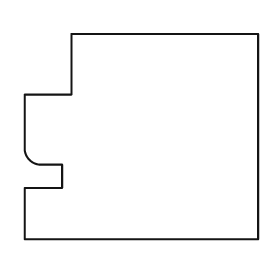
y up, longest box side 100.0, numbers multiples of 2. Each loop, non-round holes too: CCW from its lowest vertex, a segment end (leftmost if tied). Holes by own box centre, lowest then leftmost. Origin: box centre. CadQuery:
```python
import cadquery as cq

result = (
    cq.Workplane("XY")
    .moveTo(-50.0, -44.0)
    .lineTo(50.0, -44.0)
    .lineTo(50.0, 44.0)
    .lineTo(-30.0, 44.0)
    .lineTo(-30.0, 18.0)
    .lineTo(-50.0, 18.0)
    .lineTo(-50.0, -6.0)
    .threePointArc((-48.0, -10.0), (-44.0, -12.0))
    .lineTo(-34.0, -12.0)
    .lineTo(-34.0, -22.0)
    .lineTo(-50.0, -22.0)
    .close()
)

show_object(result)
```